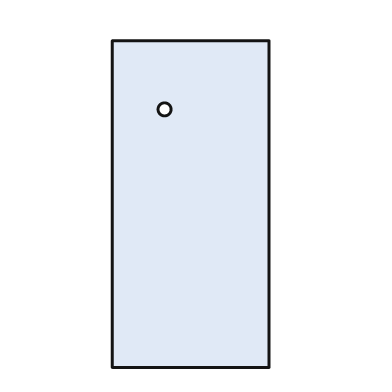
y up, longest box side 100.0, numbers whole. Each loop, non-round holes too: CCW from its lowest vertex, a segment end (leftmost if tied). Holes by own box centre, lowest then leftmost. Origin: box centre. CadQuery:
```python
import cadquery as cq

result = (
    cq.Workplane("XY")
    .moveTo(-24.0, -50.0)
    .lineTo(24.0, -50.0)
    .lineTo(24.0, 50.0)
    .lineTo(-24.0, 50.0)
    .close()
    .moveTo(-8.0, 29.0)
    .circle(2.0)
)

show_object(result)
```